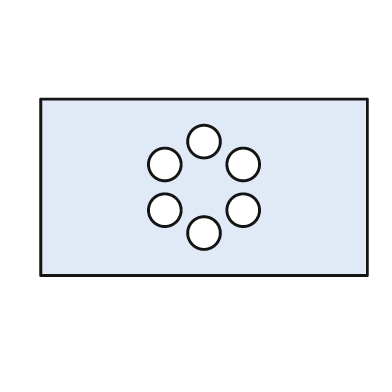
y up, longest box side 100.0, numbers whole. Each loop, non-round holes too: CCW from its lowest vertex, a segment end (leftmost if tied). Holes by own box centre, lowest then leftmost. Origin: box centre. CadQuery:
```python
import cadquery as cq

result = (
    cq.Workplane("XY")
    .moveTo(-50.0, -27.0)
    .lineTo(50.0, -27.0)
    .lineTo(50.0, 27.0)
    .lineTo(-50.0, 27.0)
    .close()
    .moveTo(0.0, -14.0)
    .circle(5.0)
    .moveTo(-12.0, -7.0)
    .circle(5.0)
    .moveTo(12.0, -7.0)
    .circle(5.0)
    .moveTo(-12.0, 7.0)
    .circle(5.0)
    .moveTo(12.0, 7.0)
    .circle(5.0)
    .moveTo(0.0, 14.0)
    .circle(5.0)
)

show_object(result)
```